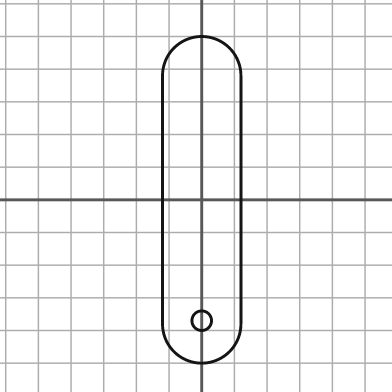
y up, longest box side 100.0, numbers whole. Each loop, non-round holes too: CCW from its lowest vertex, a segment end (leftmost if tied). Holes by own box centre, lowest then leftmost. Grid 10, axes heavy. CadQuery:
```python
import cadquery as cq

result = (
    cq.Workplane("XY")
    .moveTo(-12.0, -38.0)
    .threePointArc((0.0, -50.0), (12.0, -38.0))
    .lineTo(12.0, 38.0)
    .threePointArc((0.0, 50.0), (-12.0, 38.0))
    .close()
    .moveTo(0.0, -37.0)
    .circle(3.0)
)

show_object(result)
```